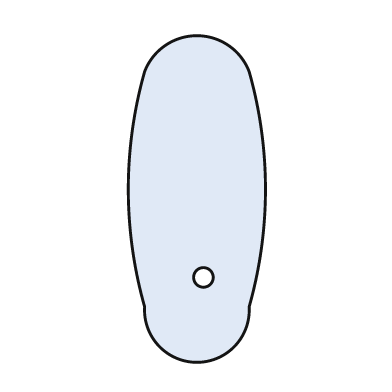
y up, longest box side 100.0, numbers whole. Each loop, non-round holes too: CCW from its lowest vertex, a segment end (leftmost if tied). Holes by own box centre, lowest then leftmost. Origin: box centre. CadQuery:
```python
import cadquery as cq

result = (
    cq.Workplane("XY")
    .moveTo(-16.0, -33.0)
    .threePointArc((0.0, -50.0), (16.0, -33.0))
    .threePointArc((21.0, 3.0), (16.0, 39.0))
    .threePointArc((0.0, 50.0), (-16.0, 39.0))
    .threePointArc((-21.0, 3.0), (-16.0, -33.0))
    .close()
    .moveTo(2.0, -24.0)
    .circle(3.0)
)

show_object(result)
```